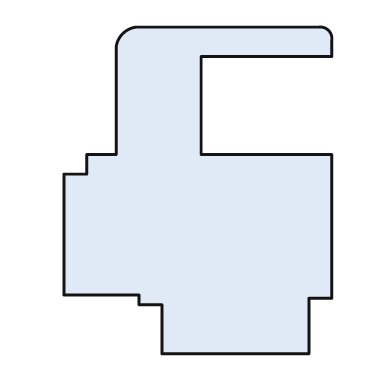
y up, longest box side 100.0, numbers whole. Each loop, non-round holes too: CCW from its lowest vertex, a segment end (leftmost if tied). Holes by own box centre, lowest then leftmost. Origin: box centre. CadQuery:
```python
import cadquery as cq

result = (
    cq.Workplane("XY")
    .moveTo(-11.0, -50.0)
    .lineTo(34.0, -50.0)
    .lineTo(34.0, -33.0)
    .lineTo(41.0, -33.0)
    .lineTo(41.0, 11.0)
    .lineTo(1.0, 11.0)
    .lineTo(1.0, 41.0)
    .lineTo(41.0, 41.0)
    .lineTo(41.0, 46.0)
    .threePointArc((40.0, 49.0), (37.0, 50.0))
    .lineTo(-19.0, 50.0)
    .threePointArc((-23.0, 48.0), (-25.0, 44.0))
    .lineTo(-25.0, 11.0)
    .lineTo(-34.0, 11.0)
    .lineTo(-34.0, 5.0)
    .lineTo(-41.0, 5.0)
    .lineTo(-41.0, -32.0)
    .lineTo(-18.0, -32.0)
    .lineTo(-18.0, -35.0)
    .lineTo(-11.0, -35.0)
    .close()
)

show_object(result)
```